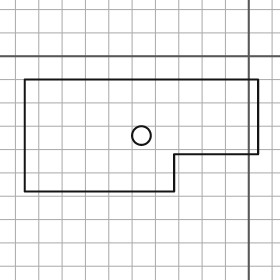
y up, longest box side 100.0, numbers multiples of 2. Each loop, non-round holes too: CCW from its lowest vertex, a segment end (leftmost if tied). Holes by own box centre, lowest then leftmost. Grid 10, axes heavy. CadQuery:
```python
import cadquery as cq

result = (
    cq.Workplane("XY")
    .moveTo(-96.0, -58.0)
    .lineTo(-32.0, -58.0)
    .lineTo(-32.0, -42.0)
    .lineTo(4.0, -42.0)
    .lineTo(4.0, -10.0)
    .lineTo(-96.0, -10.0)
    .close()
    .moveTo(-46.0, -34.0)
    .circle(4.0)
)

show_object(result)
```